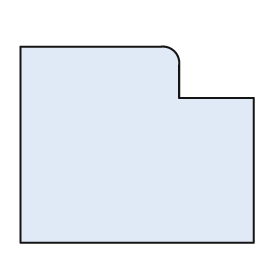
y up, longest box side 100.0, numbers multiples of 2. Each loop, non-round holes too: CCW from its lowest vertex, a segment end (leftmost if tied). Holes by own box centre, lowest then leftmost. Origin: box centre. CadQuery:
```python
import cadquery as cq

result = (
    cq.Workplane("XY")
    .moveTo(-50.0, -42.0)
    .lineTo(50.0, -42.0)
    .lineTo(50.0, 20.0)
    .lineTo(18.0, 20.0)
    .lineTo(18.0, 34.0)
    .threePointArc((16.0, 40.0), (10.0, 42.0))
    .lineTo(-50.0, 42.0)
    .close()
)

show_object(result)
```